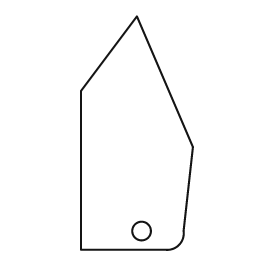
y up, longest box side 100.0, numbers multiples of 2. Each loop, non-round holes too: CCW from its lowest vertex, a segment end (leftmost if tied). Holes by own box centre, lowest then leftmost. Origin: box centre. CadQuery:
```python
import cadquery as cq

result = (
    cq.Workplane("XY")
    .moveTo(-24.0, -50.0)
    .lineTo(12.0, -50.0)
    .threePointArc((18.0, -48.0), (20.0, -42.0))
    .lineTo(24.0, -6.0)
    .lineTo(0.0, 50.0)
    .lineTo(-24.0, 18.0)
    .close()
    .moveTo(2.0, -42.0)
    .circle(4.0)
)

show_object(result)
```